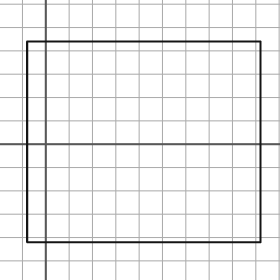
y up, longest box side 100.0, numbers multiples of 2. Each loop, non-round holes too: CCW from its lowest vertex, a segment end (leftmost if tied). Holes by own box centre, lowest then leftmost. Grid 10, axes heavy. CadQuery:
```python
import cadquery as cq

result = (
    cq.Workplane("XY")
    .moveTo(-8.0, -42.0)
    .lineTo(92.0, -42.0)
    .lineTo(92.0, 44.0)
    .lineTo(-8.0, 44.0)
    .close()
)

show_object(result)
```